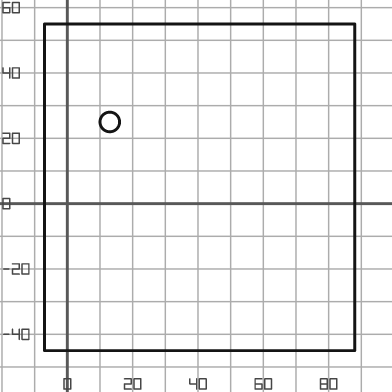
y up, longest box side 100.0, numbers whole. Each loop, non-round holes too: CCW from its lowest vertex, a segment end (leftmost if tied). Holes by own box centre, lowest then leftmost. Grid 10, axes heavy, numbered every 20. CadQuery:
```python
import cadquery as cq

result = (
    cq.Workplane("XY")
    .moveTo(-7.0, -45.0)
    .lineTo(88.0, -45.0)
    .lineTo(88.0, 55.0)
    .lineTo(-7.0, 55.0)
    .close()
    .moveTo(13.0, 25.0)
    .circle(3.0)
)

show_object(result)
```